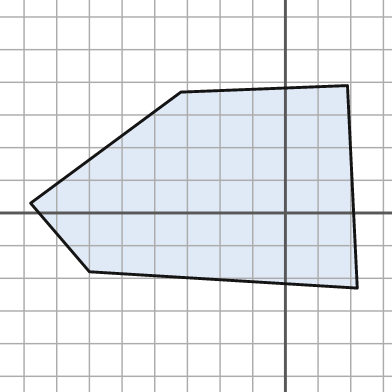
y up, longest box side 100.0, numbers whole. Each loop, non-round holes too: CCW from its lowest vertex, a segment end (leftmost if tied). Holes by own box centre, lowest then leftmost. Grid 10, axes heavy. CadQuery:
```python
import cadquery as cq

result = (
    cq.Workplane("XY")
    .moveTo(22.0, -23.0)
    .lineTo(19.0, 39.0)
    .lineTo(-32.0, 37.0)
    .lineTo(-78.0, 3.0)
    .lineTo(-60.0, -18.0)
    .close()
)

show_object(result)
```